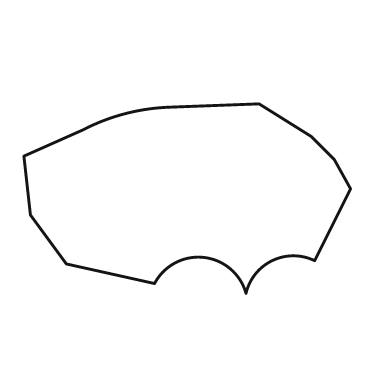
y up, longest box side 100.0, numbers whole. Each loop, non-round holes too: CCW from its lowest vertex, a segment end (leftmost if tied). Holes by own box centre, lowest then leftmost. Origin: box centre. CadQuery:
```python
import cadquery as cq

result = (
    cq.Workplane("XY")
    .moveTo(18.0, -29.0)
    .threePointArc((26.0, -19.0), (39.0, -19.0))
    .lineTo(50.0, 3.0)
    .lineTo(45.0, 12.0)
    .lineTo(38.0, 19.0)
    .lineTo(22.0, 29.0)
    .lineTo(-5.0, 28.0)
    .threePointArc((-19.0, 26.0), (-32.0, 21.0))
    .lineTo(-50.0, 13.0)
    .lineTo(-48.0, -5.0)
    .lineTo(-37.0, -20.0)
    .lineTo(-10.0, -26.0)
    .threePointArc((5.0, -18.0), (18.0, -29.0))
    .close()
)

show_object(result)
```